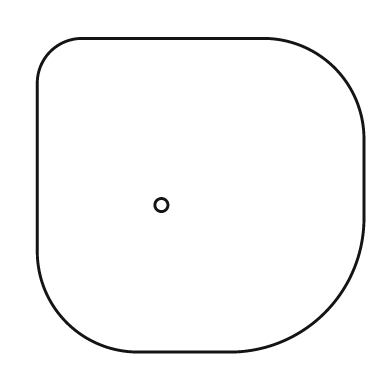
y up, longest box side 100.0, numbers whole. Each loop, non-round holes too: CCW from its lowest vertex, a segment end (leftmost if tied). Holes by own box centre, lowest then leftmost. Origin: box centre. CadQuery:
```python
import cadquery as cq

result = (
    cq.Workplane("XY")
    .moveTo(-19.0, -48.0)
    .lineTo(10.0, -48.0)
    .threePointArc((38.0, -36.0), (50.0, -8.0))
    .lineTo(50.0, 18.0)
    .threePointArc((41.0, 39.0), (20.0, 48.0))
    .lineTo(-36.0, 48.0)
    .threePointArc((-46.0, 44.0), (-50.0, 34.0))
    .lineTo(-50.0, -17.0)
    .threePointArc((-41.0, -39.0), (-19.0, -48.0))
    .close()
    .moveTo(-12.0, -3.0)
    .circle(2.0)
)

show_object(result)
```